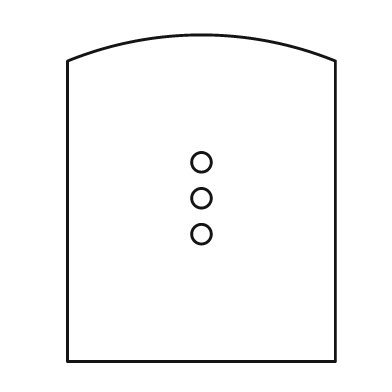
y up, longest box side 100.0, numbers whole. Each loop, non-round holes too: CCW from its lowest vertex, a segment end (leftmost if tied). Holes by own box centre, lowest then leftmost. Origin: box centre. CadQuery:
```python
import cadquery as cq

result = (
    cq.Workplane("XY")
    .moveTo(-41.0, -50.0)
    .lineTo(41.0, -50.0)
    .lineTo(41.0, 42.0)
    .threePointArc((0.0, 50.0), (-41.0, 42.0))
    .close()
    .moveTo(0.0, -11.0)
    .circle(3.0)
    .moveTo(0.0, 0.0)
    .circle(3.0)
    .moveTo(0.0, 11.0)
    .circle(3.0)
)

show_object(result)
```